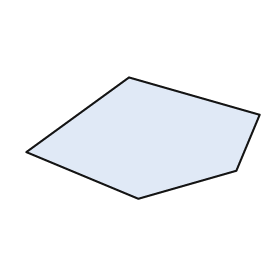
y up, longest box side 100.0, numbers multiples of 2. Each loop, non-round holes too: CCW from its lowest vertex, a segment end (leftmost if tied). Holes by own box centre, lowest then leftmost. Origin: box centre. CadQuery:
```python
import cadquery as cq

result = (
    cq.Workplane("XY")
    .moveTo(-2.0, -26.0)
    .lineTo(40.0, -14.0)
    .lineTo(50.0, 10.0)
    .lineTo(-6.0, 26.0)
    .lineTo(-50.0, -6.0)
    .close()
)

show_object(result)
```